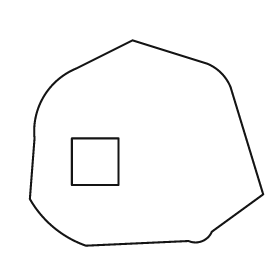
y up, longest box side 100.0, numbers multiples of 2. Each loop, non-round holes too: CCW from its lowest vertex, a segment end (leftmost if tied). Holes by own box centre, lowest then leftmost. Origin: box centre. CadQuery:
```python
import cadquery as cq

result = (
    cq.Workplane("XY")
    .moveTo(-26.0, -44.0)
    .lineTo(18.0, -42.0)
    .threePointArc((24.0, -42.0), (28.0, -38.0))
    .lineTo(50.0, -22.0)
    .lineTo(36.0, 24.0)
    .threePointArc((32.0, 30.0), (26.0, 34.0))
    .lineTo(-6.0, 44.0)
    .lineTo(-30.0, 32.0)
    .threePointArc((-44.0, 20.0), (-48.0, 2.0))
    .lineTo(-50.0, -24.0)
    .threePointArc((-40.0, -36.0), (-26.0, -44.0))
    .close()
    .moveTo(-32.0, -18.0)
    .lineTo(-12.0, -18.0)
    .lineTo(-12.0, 2.0)
    .lineTo(-32.0, 2.0)
    .close()
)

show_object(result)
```